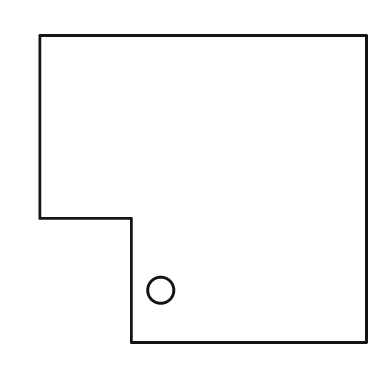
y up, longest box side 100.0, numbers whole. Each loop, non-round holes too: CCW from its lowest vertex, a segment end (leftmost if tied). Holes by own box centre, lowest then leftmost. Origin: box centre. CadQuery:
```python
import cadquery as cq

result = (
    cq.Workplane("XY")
    .moveTo(-22.0, -47.0)
    .lineTo(50.0, -47.0)
    .lineTo(50.0, 47.0)
    .lineTo(-50.0, 47.0)
    .lineTo(-50.0, -9.0)
    .lineTo(-22.0, -9.0)
    .close()
    .moveTo(-13.0, -31.0)
    .circle(4.0)
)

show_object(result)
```